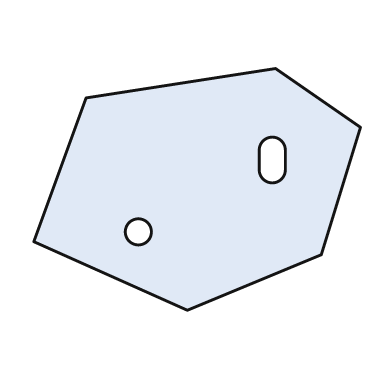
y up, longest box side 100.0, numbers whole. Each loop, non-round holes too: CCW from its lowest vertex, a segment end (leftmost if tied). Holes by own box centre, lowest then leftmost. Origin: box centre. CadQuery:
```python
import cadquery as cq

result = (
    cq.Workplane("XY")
    .moveTo(-3.0, -37.0)
    .lineTo(38.0, -20.0)
    .lineTo(50.0, 19.0)
    .lineTo(24.0, 37.0)
    .lineTo(-34.0, 28.0)
    .lineTo(-50.0, -16.0)
    .close()
    .moveTo(-18.0, -13.0)
    .circle(4.0)
    .moveTo(19.0, 6.0)
    .threePointArc((23.0, 2.0), (27.0, 6.0))
    .lineTo(27.0, 12.0)
    .threePointArc((23.0, 16.0), (19.0, 12.0))
    .close()
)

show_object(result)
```